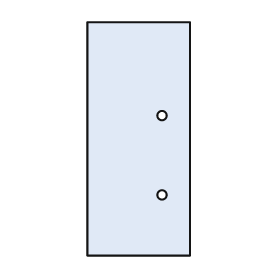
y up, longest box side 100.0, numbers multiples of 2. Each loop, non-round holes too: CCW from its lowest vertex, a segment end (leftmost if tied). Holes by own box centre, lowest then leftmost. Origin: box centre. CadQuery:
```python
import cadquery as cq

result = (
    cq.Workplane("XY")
    .moveTo(-22.0, -50.0)
    .lineTo(22.0, -50.0)
    .lineTo(22.0, 50.0)
    .lineTo(-22.0, 50.0)
    .close()
    .moveTo(10.0, -24.0)
    .circle(2.0)
    .moveTo(10.0, 10.0)
    .circle(2.0)
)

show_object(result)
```